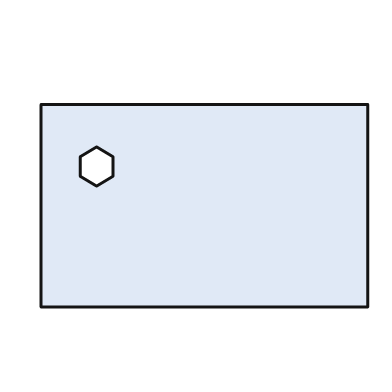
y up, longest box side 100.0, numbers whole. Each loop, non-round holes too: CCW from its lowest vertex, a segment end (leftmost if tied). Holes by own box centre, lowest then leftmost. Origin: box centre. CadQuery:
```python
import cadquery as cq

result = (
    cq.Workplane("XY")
    .moveTo(-50.0, -31.0)
    .lineTo(50.0, -31.0)
    .lineTo(50.0, 31.0)
    .lineTo(-50.0, 31.0)
    .close()
    .moveTo(-33.0, 6.0)
    .lineTo(-28.0, 9.0)
    .lineTo(-28.0, 15.0)
    .lineTo(-33.0, 18.0)
    .lineTo(-38.0, 15.0)
    .lineTo(-38.0, 9.0)
    .close()
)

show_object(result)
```